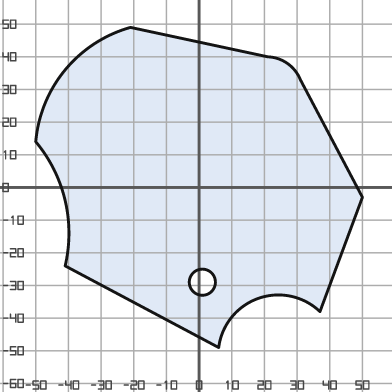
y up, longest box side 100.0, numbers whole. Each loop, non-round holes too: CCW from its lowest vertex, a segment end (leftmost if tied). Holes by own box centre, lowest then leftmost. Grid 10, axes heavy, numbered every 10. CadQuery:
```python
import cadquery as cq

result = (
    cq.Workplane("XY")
    .moveTo(6.0, -49.0)
    .threePointArc((18.0, -34.0), (37.0, -38.0))
    .lineTo(50.0, -3.0)
    .lineTo(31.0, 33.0)
    .threePointArc((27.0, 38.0), (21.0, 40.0))
    .lineTo(-21.0, 49.0)
    .threePointArc((-41.0, 36.0), (-50.0, 14.0))
    .threePointArc((-41.0, -4.0), (-41.0, -24.0))
    .close()
    .moveTo(1.0, -29.0)
    .circle(4.0)
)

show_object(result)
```